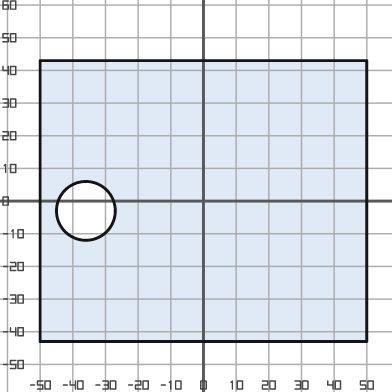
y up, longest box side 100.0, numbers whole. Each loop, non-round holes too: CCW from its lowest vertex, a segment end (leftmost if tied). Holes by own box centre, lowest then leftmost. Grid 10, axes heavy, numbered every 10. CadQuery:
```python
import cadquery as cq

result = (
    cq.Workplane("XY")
    .moveTo(-50.0, -43.0)
    .lineTo(50.0, -43.0)
    .lineTo(50.0, 43.0)
    .lineTo(-50.0, 43.0)
    .close()
    .moveTo(-36.0, -3.0)
    .circle(9.0)
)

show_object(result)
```